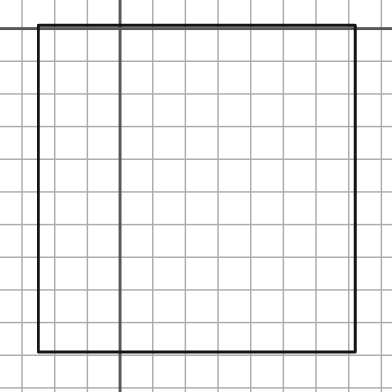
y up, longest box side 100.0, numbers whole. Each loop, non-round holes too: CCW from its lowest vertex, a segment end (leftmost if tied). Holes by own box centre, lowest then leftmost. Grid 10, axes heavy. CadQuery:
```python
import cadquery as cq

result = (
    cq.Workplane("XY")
    .moveTo(-25.0, -99.0)
    .lineTo(72.0, -99.0)
    .lineTo(72.0, 1.0)
    .lineTo(-25.0, 1.0)
    .close()
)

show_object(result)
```